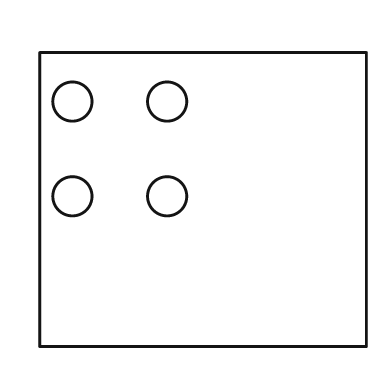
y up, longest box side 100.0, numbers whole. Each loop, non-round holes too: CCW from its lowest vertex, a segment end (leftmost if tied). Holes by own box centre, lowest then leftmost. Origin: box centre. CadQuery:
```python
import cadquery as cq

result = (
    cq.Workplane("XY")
    .moveTo(-50.0, -45.0)
    .lineTo(50.0, -45.0)
    .lineTo(50.0, 45.0)
    .lineTo(-50.0, 45.0)
    .close()
    .moveTo(-40.0, 1.0)
    .circle(6.0)
    .moveTo(-11.0, 1.0)
    .circle(6.0)
    .moveTo(-40.0, 30.0)
    .circle(6.0)
    .moveTo(-11.0, 30.0)
    .circle(6.0)
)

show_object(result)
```